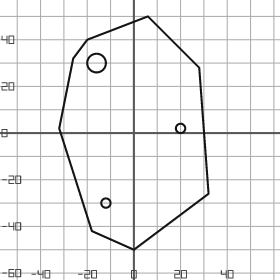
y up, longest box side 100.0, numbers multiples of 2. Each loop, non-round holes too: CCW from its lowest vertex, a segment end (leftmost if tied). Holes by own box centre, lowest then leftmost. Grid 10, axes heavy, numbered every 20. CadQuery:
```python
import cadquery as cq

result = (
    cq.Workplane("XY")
    .moveTo(0.0, -50.0)
    .lineTo(32.0, -26.0)
    .lineTo(28.0, 28.0)
    .lineTo(6.0, 50.0)
    .lineTo(-20.0, 40.0)
    .lineTo(-26.0, 32.0)
    .lineTo(-32.0, 2.0)
    .lineTo(-18.0, -42.0)
    .close()
    .moveTo(-12.0, -30.0)
    .circle(2.0)
    .moveTo(20.0, 2.0)
    .circle(2.0)
    .moveTo(-16.0, 30.0)
    .circle(4.0)
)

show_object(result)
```